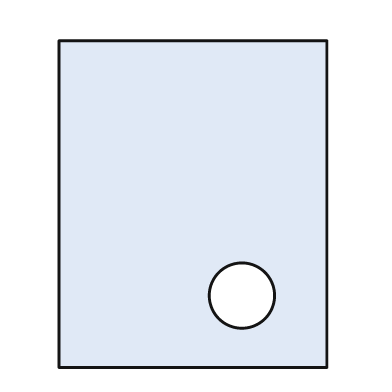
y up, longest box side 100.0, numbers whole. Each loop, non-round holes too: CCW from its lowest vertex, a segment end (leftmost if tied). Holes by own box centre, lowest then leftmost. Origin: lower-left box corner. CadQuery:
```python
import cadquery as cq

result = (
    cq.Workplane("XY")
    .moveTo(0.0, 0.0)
    .lineTo(82.0, 0.0)
    .lineTo(82.0, 100.0)
    .lineTo(0.0, 100.0)
    .close()
    .moveTo(56.0, 22.0)
    .circle(10.0)
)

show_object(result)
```